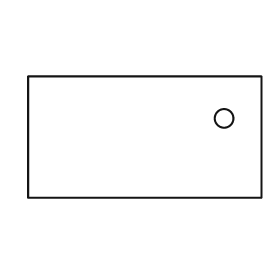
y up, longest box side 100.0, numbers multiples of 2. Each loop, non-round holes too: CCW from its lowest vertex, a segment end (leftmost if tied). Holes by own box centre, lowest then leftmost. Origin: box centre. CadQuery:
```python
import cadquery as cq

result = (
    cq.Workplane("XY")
    .moveTo(-50.0, -26.0)
    .lineTo(50.0, -26.0)
    .lineTo(50.0, 26.0)
    .lineTo(-50.0, 26.0)
    .close()
    .moveTo(34.0, 8.0)
    .circle(4.0)
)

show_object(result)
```